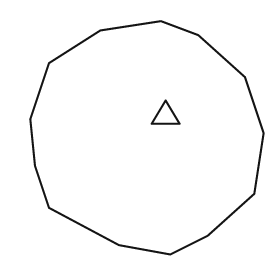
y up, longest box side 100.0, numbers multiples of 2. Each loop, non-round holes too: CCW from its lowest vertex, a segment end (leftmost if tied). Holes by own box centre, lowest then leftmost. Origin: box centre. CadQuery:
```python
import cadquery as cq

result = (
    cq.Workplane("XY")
    .moveTo(10.0, -50.0)
    .lineTo(26.0, -42.0)
    .lineTo(46.0, -24.0)
    .lineTo(50.0, 2.0)
    .lineTo(42.0, 26.0)
    .lineTo(22.0, 44.0)
    .lineTo(6.0, 50.0)
    .lineTo(-20.0, 46.0)
    .lineTo(-42.0, 32.0)
    .lineTo(-50.0, 8.0)
    .lineTo(-48.0, -12.0)
    .lineTo(-42.0, -30.0)
    .lineTo(-12.0, -46.0)
    .close()
    .moveTo(2.0, 6.0)
    .lineTo(14.0, 6.0)
    .lineTo(8.0, 16.0)
    .close()
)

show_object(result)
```